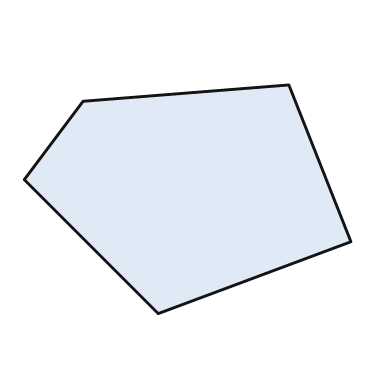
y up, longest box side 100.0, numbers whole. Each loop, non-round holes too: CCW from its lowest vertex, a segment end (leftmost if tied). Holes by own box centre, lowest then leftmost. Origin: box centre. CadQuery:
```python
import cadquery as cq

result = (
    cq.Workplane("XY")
    .moveTo(-9.0, -35.0)
    .lineTo(50.0, -13.0)
    .lineTo(31.0, 35.0)
    .lineTo(-32.0, 30.0)
    .lineTo(-50.0, 6.0)
    .close()
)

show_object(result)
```